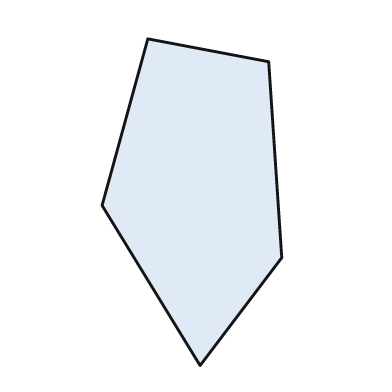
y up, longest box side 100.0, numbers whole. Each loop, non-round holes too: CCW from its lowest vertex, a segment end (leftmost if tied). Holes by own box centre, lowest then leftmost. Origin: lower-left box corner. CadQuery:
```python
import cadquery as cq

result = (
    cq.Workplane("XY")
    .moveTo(30.0, 0.0)
    .lineTo(55.0, 33.0)
    .lineTo(51.0, 93.0)
    .lineTo(14.0, 100.0)
    .lineTo(0.0, 49.0)
    .close()
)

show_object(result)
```